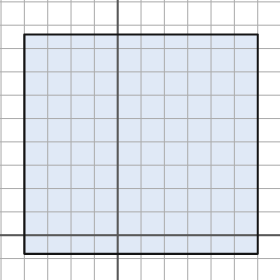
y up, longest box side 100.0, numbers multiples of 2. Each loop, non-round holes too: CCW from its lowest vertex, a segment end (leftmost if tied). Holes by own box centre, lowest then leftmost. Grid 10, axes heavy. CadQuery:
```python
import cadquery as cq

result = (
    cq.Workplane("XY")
    .moveTo(-40.0, -8.0)
    .lineTo(60.0, -8.0)
    .lineTo(60.0, 86.0)
    .lineTo(-40.0, 86.0)
    .close()
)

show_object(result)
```